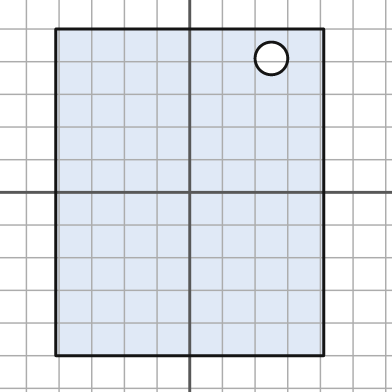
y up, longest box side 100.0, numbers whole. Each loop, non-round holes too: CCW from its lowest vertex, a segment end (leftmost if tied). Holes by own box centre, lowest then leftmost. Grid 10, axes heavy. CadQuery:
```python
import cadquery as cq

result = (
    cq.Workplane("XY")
    .moveTo(-41.0, -50.0)
    .lineTo(41.0, -50.0)
    .lineTo(41.0, 50.0)
    .lineTo(-41.0, 50.0)
    .close()
    .moveTo(25.0, 41.0)
    .circle(5.0)
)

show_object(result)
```